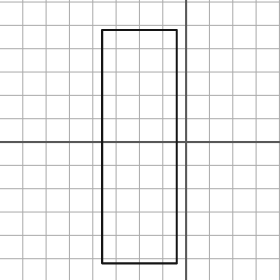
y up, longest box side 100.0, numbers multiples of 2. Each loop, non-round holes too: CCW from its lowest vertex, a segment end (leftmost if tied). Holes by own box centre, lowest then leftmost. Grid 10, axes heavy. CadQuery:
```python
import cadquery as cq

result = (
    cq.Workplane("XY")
    .moveTo(-36.0, -52.0)
    .lineTo(-4.0, -52.0)
    .lineTo(-4.0, 48.0)
    .lineTo(-36.0, 48.0)
    .close()
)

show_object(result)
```